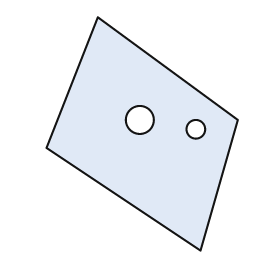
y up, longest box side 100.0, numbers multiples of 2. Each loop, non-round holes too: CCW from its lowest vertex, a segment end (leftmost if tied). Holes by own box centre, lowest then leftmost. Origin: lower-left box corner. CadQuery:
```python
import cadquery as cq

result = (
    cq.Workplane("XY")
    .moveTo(66.0, 0.0)
    .lineTo(82.0, 56.0)
    .lineTo(22.0, 100.0)
    .lineTo(0.0, 44.0)
    .close()
    .moveTo(64.0, 52.0)
    .circle(4.0)
    .moveTo(40.0, 56.0)
    .circle(6.0)
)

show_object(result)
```